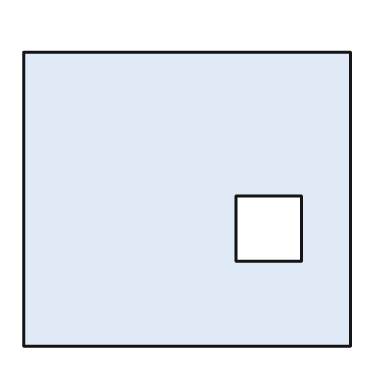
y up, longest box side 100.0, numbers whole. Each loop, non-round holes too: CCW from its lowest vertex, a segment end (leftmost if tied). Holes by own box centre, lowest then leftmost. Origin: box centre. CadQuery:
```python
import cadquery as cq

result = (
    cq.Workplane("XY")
    .moveTo(-50.0, -45.0)
    .lineTo(50.0, -45.0)
    .lineTo(50.0, 45.0)
    .lineTo(-50.0, 45.0)
    .close()
    .moveTo(15.0, -19.0)
    .lineTo(35.0, -19.0)
    .lineTo(35.0, 1.0)
    .lineTo(15.0, 1.0)
    .close()
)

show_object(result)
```